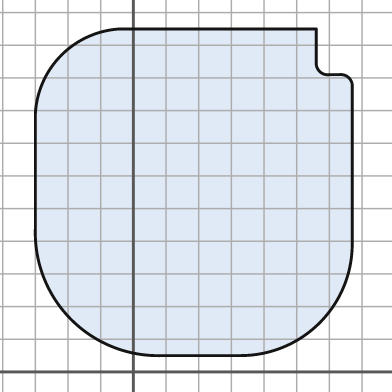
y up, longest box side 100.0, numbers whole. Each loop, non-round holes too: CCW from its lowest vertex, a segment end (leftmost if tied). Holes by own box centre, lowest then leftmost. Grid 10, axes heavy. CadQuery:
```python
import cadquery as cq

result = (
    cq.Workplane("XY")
    .moveTo(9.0, 5.0)
    .lineTo(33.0, 5.0)
    .threePointArc((57.0, 15.0), (67.0, 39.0))
    .lineTo(67.0, 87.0)
    .threePointArc((66.0, 90.0), (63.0, 91.0))
    .lineTo(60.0, 91.0)
    .threePointArc((57.0, 92.0), (56.0, 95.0))
    .lineTo(56.0, 105.0)
    .lineTo(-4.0, 105.0)
    .threePointArc((-22.0, 97.0), (-30.0, 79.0))
    .lineTo(-30.0, 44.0)
    .threePointArc((-19.0, 16.0), (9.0, 5.0))
    .close()
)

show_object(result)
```